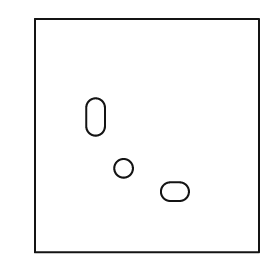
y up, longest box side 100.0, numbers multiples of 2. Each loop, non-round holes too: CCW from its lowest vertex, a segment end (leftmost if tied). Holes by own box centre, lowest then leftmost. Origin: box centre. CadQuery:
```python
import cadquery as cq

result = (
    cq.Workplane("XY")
    .moveTo(-48.0, -50.0)
    .lineTo(48.0, -50.0)
    .lineTo(48.0, 50.0)
    .lineTo(-48.0, 50.0)
    .close()
    .moveTo(10.0, -28.0)
    .lineTo(14.0, -28.0)
    .threePointArc((18.0, -24.0), (14.0, -20.0))
    .lineTo(10.0, -20.0)
    .threePointArc((6.0, -24.0), (10.0, -28.0))
    .close()
    .moveTo(-10.0, -14.0)
    .circle(4.0)
    .moveTo(-26.0, 4.0)
    .threePointArc((-22.0, 0.0), (-18.0, 4.0))
    .lineTo(-18.0, 12.0)
    .threePointArc((-22.0, 16.0), (-26.0, 12.0))
    .close()
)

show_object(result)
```